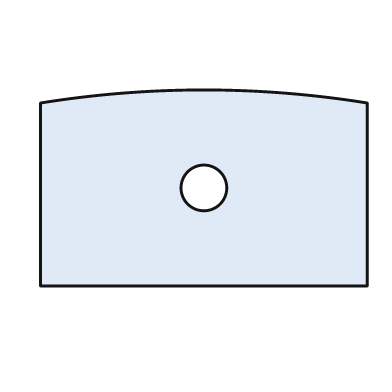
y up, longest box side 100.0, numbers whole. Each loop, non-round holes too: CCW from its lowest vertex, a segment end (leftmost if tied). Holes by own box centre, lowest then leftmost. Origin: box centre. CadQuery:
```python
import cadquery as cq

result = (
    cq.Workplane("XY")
    .moveTo(-50.0, -30.0)
    .lineTo(50.0, -30.0)
    .lineTo(50.0, 26.0)
    .threePointArc((0.0, 30.0), (-50.0, 26.0))
    .close()
    .moveTo(0.0, 0.0)
    .circle(7.0)
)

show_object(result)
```